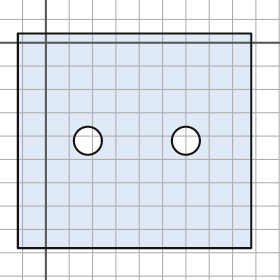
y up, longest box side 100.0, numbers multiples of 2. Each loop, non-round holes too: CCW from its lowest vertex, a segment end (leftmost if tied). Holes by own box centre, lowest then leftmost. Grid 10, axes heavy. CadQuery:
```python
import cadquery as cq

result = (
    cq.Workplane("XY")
    .moveTo(-12.0, -88.0)
    .lineTo(88.0, -88.0)
    .lineTo(88.0, 4.0)
    .lineTo(-12.0, 4.0)
    .close()
    .moveTo(18.0, -42.0)
    .circle(6.0)
    .moveTo(60.0, -42.0)
    .circle(6.0)
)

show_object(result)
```